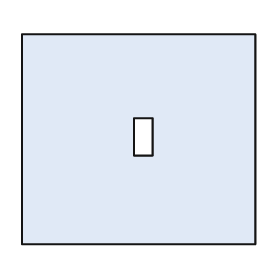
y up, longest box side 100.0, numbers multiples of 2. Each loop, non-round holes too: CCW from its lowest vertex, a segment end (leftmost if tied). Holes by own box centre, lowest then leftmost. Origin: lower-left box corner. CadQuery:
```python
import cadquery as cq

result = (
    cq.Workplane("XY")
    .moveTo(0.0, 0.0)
    .lineTo(100.0, 0.0)
    .lineTo(100.0, 90.0)
    .lineTo(0.0, 90.0)
    .close()
    .moveTo(48.0, 38.0)
    .lineTo(56.0, 38.0)
    .lineTo(56.0, 54.0)
    .lineTo(48.0, 54.0)
    .close()
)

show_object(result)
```